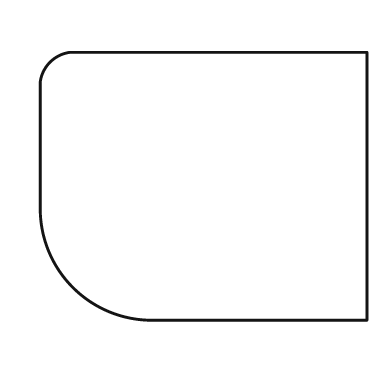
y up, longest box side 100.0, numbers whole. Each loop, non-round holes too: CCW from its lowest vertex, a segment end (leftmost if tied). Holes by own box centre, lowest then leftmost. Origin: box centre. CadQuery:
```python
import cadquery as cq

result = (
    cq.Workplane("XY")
    .moveTo(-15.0, -41.0)
    .lineTo(50.0, -41.0)
    .lineTo(50.0, 41.0)
    .lineTo(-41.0, 41.0)
    .threePointArc((-47.0, 38.0), (-50.0, 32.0))
    .lineTo(-50.0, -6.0)
    .threePointArc((-40.0, -31.0), (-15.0, -41.0))
    .close()
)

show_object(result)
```